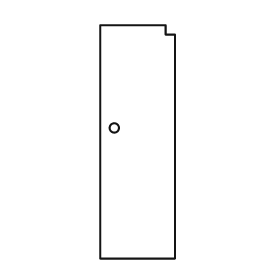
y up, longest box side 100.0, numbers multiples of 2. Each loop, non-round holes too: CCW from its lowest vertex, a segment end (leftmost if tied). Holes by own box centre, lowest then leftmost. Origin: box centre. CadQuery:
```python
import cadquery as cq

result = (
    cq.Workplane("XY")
    .moveTo(-16.0, -50.0)
    .lineTo(16.0, -50.0)
    .lineTo(16.0, 46.0)
    .lineTo(12.0, 46.0)
    .lineTo(12.0, 50.0)
    .lineTo(-16.0, 50.0)
    .close()
    .moveTo(-10.0, 6.0)
    .circle(2.0)
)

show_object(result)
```